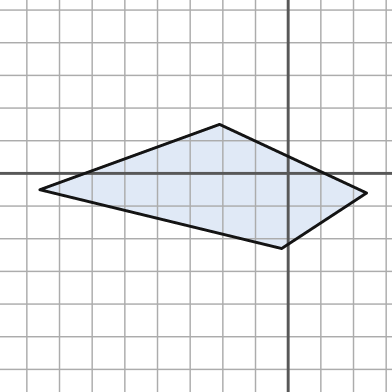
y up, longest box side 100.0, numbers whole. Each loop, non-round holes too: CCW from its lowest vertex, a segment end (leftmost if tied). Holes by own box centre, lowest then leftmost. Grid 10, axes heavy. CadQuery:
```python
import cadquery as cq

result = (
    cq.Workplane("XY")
    .moveTo(-2.0, -23.0)
    .lineTo(24.0, -6.0)
    .lineTo(-21.0, 15.0)
    .lineTo(-76.0, -5.0)
    .close()
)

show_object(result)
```